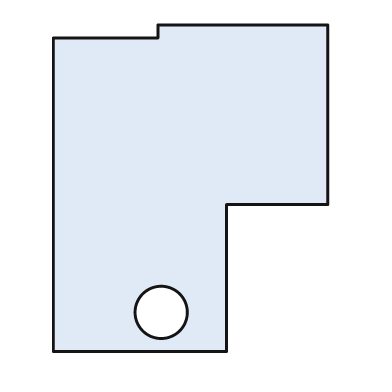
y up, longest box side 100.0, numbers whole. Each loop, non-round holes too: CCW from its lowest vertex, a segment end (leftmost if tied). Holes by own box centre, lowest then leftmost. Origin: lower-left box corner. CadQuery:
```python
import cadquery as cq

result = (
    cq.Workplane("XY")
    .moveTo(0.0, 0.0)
    .lineTo(53.0, 0.0)
    .lineTo(53.0, 45.0)
    .lineTo(84.0, 45.0)
    .lineTo(84.0, 100.0)
    .lineTo(32.0, 100.0)
    .lineTo(32.0, 96.0)
    .lineTo(0.0, 96.0)
    .close()
    .moveTo(33.0, 12.0)
    .circle(8.0)
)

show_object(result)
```